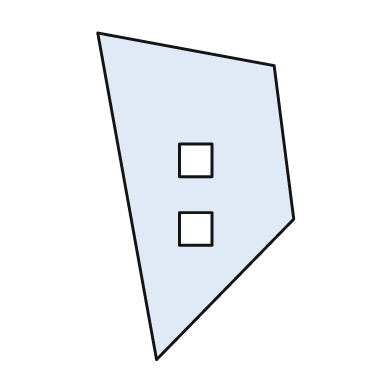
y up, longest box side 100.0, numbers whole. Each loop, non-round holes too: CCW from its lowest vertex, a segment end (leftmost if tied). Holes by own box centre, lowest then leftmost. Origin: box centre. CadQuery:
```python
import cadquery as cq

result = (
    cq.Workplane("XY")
    .moveTo(-12.0, -50.0)
    .lineTo(30.0, -7.0)
    .lineTo(24.0, 40.0)
    .lineTo(-30.0, 50.0)
    .close()
    .moveTo(-5.0, -15.0)
    .lineTo(5.0, -15.0)
    .lineTo(5.0, -5.0)
    .lineTo(-5.0, -5.0)
    .close()
    .moveTo(-5.0, 6.0)
    .lineTo(5.0, 6.0)
    .lineTo(5.0, 16.0)
    .lineTo(-5.0, 16.0)
    .close()
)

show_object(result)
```